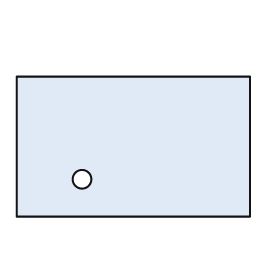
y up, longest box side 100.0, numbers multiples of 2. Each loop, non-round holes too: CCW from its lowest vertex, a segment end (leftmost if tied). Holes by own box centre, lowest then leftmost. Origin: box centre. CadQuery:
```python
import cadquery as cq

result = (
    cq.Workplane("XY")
    .moveTo(-50.0, -30.0)
    .lineTo(50.0, -30.0)
    .lineTo(50.0, 30.0)
    .lineTo(-50.0, 30.0)
    .close()
    .moveTo(-22.0, -14.0)
    .circle(4.0)
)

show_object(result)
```